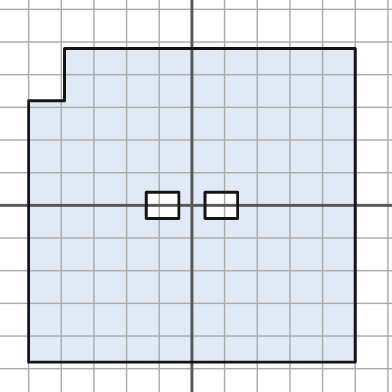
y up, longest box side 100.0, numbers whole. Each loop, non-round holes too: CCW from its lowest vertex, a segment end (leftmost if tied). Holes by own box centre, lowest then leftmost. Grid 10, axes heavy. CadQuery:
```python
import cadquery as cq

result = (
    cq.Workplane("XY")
    .moveTo(-50.0, -48.0)
    .lineTo(50.0, -48.0)
    .lineTo(50.0, 48.0)
    .lineTo(-39.0, 48.0)
    .lineTo(-39.0, 32.0)
    .lineTo(-50.0, 32.0)
    .close()
    .moveTo(-14.0, -4.0)
    .lineTo(-4.0, -4.0)
    .lineTo(-4.0, 4.0)
    .lineTo(-14.0, 4.0)
    .close()
    .moveTo(4.0, -4.0)
    .lineTo(14.0, -4.0)
    .lineTo(14.0, 4.0)
    .lineTo(4.0, 4.0)
    .close()
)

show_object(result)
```